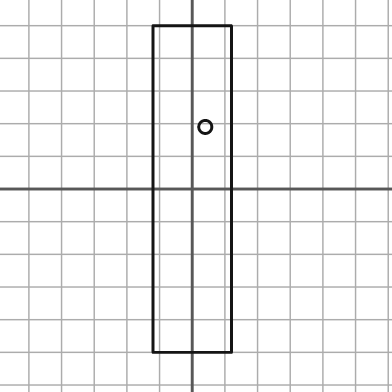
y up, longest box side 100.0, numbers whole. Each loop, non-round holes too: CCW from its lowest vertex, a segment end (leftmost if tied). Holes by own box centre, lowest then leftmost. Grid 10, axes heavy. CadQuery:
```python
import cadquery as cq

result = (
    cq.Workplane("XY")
    .moveTo(-12.0, -50.0)
    .lineTo(12.0, -50.0)
    .lineTo(12.0, 50.0)
    .lineTo(-12.0, 50.0)
    .close()
    .moveTo(4.0, 19.0)
    .circle(2.0)
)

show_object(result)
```